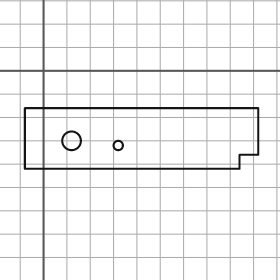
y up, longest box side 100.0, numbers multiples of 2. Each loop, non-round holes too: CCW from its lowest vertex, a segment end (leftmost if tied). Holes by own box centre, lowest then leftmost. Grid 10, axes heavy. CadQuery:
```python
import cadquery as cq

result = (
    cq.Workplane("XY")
    .moveTo(-8.0, -42.0)
    .lineTo(84.0, -42.0)
    .lineTo(84.0, -36.0)
    .lineTo(92.0, -36.0)
    .lineTo(92.0, -16.0)
    .lineTo(-8.0, -16.0)
    .close()
    .moveTo(32.0, -32.0)
    .circle(2.0)
    .moveTo(12.0, -30.0)
    .circle(4.0)
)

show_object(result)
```